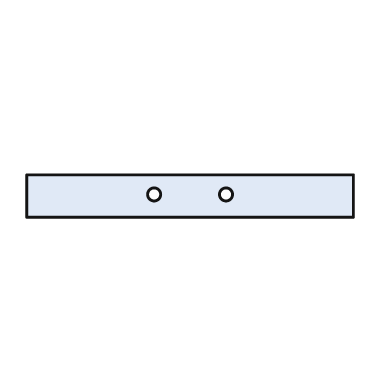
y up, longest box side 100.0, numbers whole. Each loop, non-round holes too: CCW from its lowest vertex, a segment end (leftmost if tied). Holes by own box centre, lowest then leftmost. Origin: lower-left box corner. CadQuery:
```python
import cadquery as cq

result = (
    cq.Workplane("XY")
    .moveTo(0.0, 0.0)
    .lineTo(100.0, 0.0)
    .lineTo(100.0, 13.0)
    .lineTo(0.0, 13.0)
    .close()
    .moveTo(39.0, 7.0)
    .circle(2.0)
    .moveTo(61.0, 7.0)
    .circle(2.0)
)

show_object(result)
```